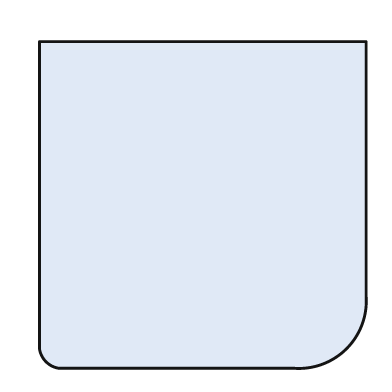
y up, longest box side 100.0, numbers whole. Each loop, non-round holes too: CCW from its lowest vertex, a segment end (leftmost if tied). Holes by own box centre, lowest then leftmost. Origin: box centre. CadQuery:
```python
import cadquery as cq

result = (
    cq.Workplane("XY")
    .moveTo(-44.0, -50.0)
    .lineTo(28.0, -50.0)
    .threePointArc((44.0, -44.0), (50.0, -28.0))
    .lineTo(50.0, 50.0)
    .lineTo(-50.0, 50.0)
    .lineTo(-50.0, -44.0)
    .threePointArc((-48.0, -48.0), (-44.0, -50.0))
    .close()
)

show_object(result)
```